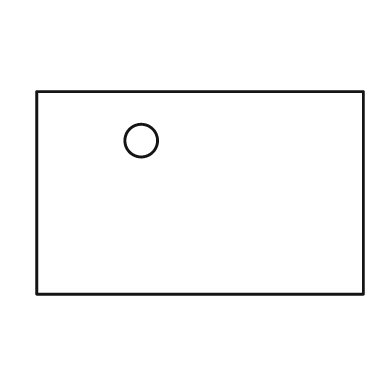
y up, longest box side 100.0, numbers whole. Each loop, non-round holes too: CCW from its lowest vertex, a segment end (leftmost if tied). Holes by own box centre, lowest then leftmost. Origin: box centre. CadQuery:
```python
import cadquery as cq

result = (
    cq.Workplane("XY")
    .moveTo(-50.0, -31.0)
    .lineTo(50.0, -31.0)
    .lineTo(50.0, 31.0)
    .lineTo(-50.0, 31.0)
    .close()
    .moveTo(-18.0, 16.0)
    .circle(5.0)
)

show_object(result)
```